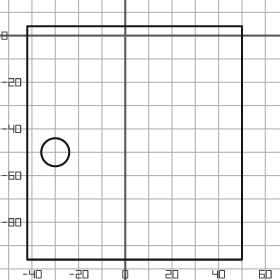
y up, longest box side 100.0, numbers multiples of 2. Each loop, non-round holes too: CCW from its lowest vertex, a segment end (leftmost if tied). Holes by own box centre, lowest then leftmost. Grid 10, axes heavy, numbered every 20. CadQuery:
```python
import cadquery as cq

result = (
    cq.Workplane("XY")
    .moveTo(-42.0, -96.0)
    .lineTo(50.0, -96.0)
    .lineTo(50.0, 4.0)
    .lineTo(-42.0, 4.0)
    .close()
    .moveTo(-30.0, -50.0)
    .circle(6.0)
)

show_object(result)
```